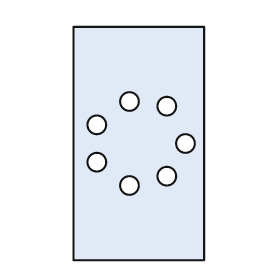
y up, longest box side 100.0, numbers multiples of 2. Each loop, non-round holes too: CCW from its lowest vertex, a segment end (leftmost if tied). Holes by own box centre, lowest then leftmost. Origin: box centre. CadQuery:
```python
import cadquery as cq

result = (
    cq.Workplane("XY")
    .moveTo(-28.0, -50.0)
    .lineTo(28.0, -50.0)
    .lineTo(28.0, 50.0)
    .lineTo(-28.0, 50.0)
    .close()
    .moveTo(-4.0, -18.0)
    .circle(4.0)
    .moveTo(12.0, -14.0)
    .circle(4.0)
    .moveTo(-18.0, -8.0)
    .circle(4.0)
    .moveTo(20.0, 0.0)
    .circle(4.0)
    .moveTo(-18.0, 8.0)
    .circle(4.0)
    .moveTo(12.0, 16.0)
    .circle(4.0)
    .moveTo(-4.0, 18.0)
    .circle(4.0)
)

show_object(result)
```